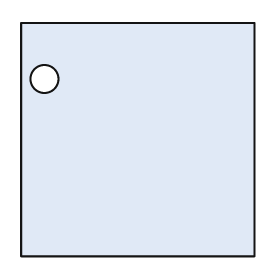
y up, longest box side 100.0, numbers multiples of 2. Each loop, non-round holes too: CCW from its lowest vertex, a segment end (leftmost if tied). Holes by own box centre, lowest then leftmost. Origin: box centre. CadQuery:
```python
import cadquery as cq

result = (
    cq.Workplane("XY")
    .moveTo(-50.0, -50.0)
    .lineTo(50.0, -50.0)
    .lineTo(50.0, 50.0)
    .lineTo(-50.0, 50.0)
    .close()
    .moveTo(-40.0, 26.0)
    .circle(6.0)
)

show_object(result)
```